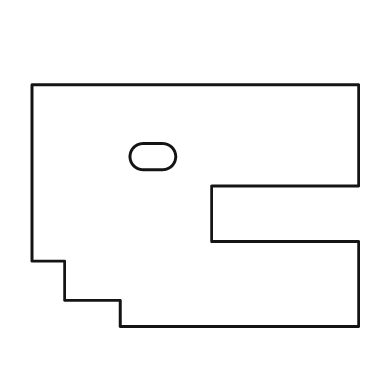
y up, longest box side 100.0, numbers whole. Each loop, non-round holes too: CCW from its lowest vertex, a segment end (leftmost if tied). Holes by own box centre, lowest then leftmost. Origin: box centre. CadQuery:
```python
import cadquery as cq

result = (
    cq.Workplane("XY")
    .moveTo(-23.0, -37.0)
    .lineTo(50.0, -37.0)
    .lineTo(50.0, -11.0)
    .lineTo(5.0, -11.0)
    .lineTo(5.0, 6.0)
    .lineTo(50.0, 6.0)
    .lineTo(50.0, 37.0)
    .lineTo(-50.0, 37.0)
    .lineTo(-50.0, -17.0)
    .lineTo(-40.0, -17.0)
    .lineTo(-40.0, -29.0)
    .lineTo(-23.0, -29.0)
    .close()
    .moveTo(-16.0, 11.0)
    .lineTo(-10.0, 11.0)
    .threePointArc((-6.0, 15.0), (-10.0, 19.0))
    .lineTo(-16.0, 19.0)
    .threePointArc((-20.0, 15.0), (-16.0, 11.0))
    .close()
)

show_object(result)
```